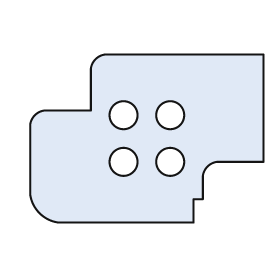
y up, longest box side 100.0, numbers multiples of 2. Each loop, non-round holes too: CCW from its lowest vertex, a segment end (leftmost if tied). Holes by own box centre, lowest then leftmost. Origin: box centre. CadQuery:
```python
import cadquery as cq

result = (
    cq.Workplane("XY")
    .moveTo(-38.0, -36.0)
    .lineTo(20.0, -36.0)
    .lineTo(20.0, -26.0)
    .lineTo(24.0, -26.0)
    .lineTo(24.0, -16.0)
    .threePointArc((26.0, -12.0), (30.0, -10.0))
    .lineTo(50.0, -10.0)
    .lineTo(50.0, 36.0)
    .lineTo(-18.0, 36.0)
    .threePointArc((-22.0, 34.0), (-24.0, 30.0))
    .lineTo(-24.0, 12.0)
    .lineTo(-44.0, 12.0)
    .threePointArc((-48.0, 10.0), (-50.0, 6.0))
    .lineTo(-50.0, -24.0)
    .threePointArc((-46.0, -32.0), (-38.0, -36.0))
    .close()
    .moveTo(-10.0, -10.0)
    .circle(6.0)
    .moveTo(10.0, -10.0)
    .circle(6.0)
    .moveTo(-10.0, 10.0)
    .circle(6.0)
    .moveTo(10.0, 10.0)
    .circle(6.0)
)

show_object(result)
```